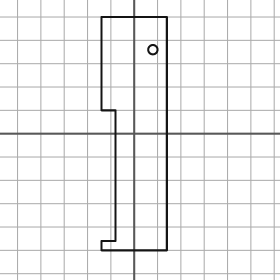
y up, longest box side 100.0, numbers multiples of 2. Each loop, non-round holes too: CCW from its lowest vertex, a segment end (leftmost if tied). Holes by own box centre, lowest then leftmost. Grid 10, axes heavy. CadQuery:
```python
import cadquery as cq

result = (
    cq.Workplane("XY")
    .moveTo(-14.0, -50.0)
    .lineTo(14.0, -50.0)
    .lineTo(14.0, 50.0)
    .lineTo(-14.0, 50.0)
    .lineTo(-14.0, 10.0)
    .lineTo(-8.0, 10.0)
    .lineTo(-8.0, -46.0)
    .lineTo(-14.0, -46.0)
    .close()
    .moveTo(8.0, 36.0)
    .circle(2.0)
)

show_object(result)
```